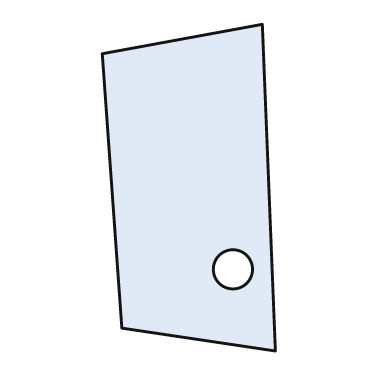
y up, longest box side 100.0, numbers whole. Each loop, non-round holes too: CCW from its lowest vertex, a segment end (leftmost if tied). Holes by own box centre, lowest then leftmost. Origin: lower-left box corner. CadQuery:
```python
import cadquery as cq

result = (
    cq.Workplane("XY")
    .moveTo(53.0, 0.0)
    .lineTo(49.0, 100.0)
    .lineTo(0.0, 91.0)
    .lineTo(6.0, 7.0)
    .close()
    .moveTo(40.0, 25.0)
    .circle(6.0)
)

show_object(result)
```